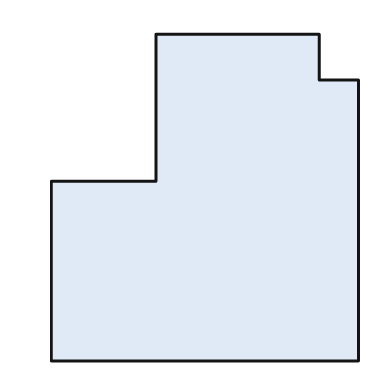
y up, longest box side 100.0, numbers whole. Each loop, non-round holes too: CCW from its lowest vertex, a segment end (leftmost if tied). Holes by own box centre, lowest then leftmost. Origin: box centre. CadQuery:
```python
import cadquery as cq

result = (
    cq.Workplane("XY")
    .moveTo(-47.0, -50.0)
    .lineTo(47.0, -50.0)
    .lineTo(47.0, 36.0)
    .lineTo(35.0, 36.0)
    .lineTo(35.0, 50.0)
    .lineTo(-15.0, 50.0)
    .lineTo(-15.0, 5.0)
    .lineTo(-47.0, 5.0)
    .close()
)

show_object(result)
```